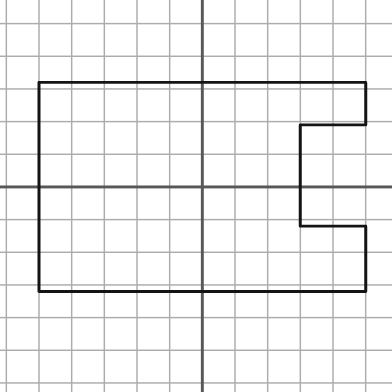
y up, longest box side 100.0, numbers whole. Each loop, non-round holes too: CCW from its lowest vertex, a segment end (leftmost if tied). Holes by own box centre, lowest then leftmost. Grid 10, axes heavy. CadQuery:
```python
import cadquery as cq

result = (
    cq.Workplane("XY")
    .moveTo(-50.0, -32.0)
    .lineTo(50.0, -32.0)
    .lineTo(50.0, -12.0)
    .lineTo(30.0, -12.0)
    .lineTo(30.0, 19.0)
    .lineTo(50.0, 19.0)
    .lineTo(50.0, 32.0)
    .lineTo(-50.0, 32.0)
    .close()
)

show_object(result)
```